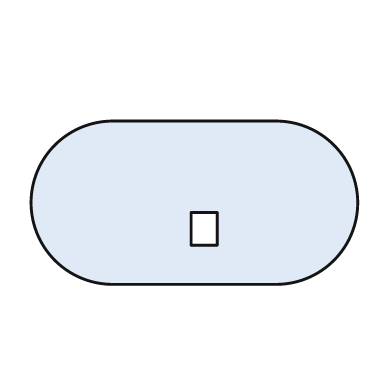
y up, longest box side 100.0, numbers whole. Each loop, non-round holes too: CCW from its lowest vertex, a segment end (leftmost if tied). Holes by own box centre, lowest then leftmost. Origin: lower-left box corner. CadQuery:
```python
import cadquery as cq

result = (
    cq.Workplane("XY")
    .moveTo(25.0, 0.0)
    .lineTo(75.0, 0.0)
    .threePointArc((100.0, 25.0), (75.0, 50.0))
    .lineTo(25.0, 50.0)
    .threePointArc((0.0, 25.0), (25.0, 0.0))
    .close()
    .moveTo(49.0, 12.0)
    .lineTo(57.0, 12.0)
    .lineTo(57.0, 22.0)
    .lineTo(49.0, 22.0)
    .close()
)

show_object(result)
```